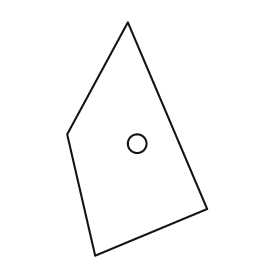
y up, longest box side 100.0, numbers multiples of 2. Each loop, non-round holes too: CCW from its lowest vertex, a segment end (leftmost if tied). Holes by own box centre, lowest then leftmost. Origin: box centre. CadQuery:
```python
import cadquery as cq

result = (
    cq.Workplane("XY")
    .moveTo(-18.0, -50.0)
    .lineTo(30.0, -30.0)
    .lineTo(-4.0, 50.0)
    .lineTo(-30.0, 2.0)
    .close()
    .moveTo(0.0, -2.0)
    .circle(4.0)
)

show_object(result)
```